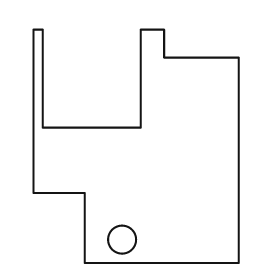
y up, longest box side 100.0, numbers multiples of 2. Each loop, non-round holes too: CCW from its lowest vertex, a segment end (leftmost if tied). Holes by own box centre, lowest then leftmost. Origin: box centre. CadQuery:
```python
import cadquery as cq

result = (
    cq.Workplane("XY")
    .moveTo(-22.0, -50.0)
    .lineTo(44.0, -50.0)
    .lineTo(44.0, 38.0)
    .lineTo(12.0, 38.0)
    .lineTo(12.0, 50.0)
    .lineTo(2.0, 50.0)
    .lineTo(2.0, 8.0)
    .lineTo(-40.0, 8.0)
    .lineTo(-40.0, 50.0)
    .lineTo(-44.0, 50.0)
    .lineTo(-44.0, -20.0)
    .lineTo(-22.0, -20.0)
    .close()
    .moveTo(-6.0, -40.0)
    .circle(6.0)
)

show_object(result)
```